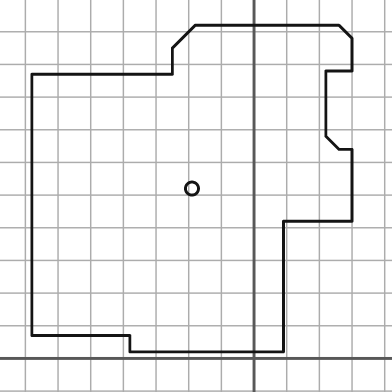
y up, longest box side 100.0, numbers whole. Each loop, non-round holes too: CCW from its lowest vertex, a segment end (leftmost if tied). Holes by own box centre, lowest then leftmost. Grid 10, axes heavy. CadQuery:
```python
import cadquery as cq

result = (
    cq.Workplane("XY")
    .moveTo(-38.0, 2.0)
    .lineTo(9.0, 2.0)
    .lineTo(9.0, 42.0)
    .lineTo(30.0, 42.0)
    .lineTo(30.0, 64.0)
    .lineTo(26.0, 64.0)
    .lineTo(22.0, 68.0)
    .lineTo(22.0, 88.0)
    .lineTo(30.0, 88.0)
    .lineTo(30.0, 98.0)
    .lineTo(26.0, 102.0)
    .lineTo(-18.0, 102.0)
    .lineTo(-25.0, 95.0)
    .lineTo(-25.0, 87.0)
    .lineTo(-68.0, 87.0)
    .lineTo(-68.0, 7.0)
    .lineTo(-38.0, 7.0)
    .close()
    .moveTo(-19.0, 52.0)
    .circle(2.0)
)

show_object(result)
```